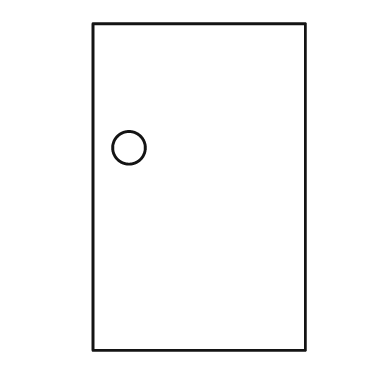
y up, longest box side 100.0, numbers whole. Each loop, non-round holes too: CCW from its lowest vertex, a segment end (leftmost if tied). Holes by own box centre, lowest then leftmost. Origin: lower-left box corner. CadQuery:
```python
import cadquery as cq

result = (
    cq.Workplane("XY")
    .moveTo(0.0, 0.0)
    .lineTo(65.0, 0.0)
    .lineTo(65.0, 100.0)
    .lineTo(0.0, 100.0)
    .close()
    .moveTo(11.0, 62.0)
    .circle(5.0)
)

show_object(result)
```